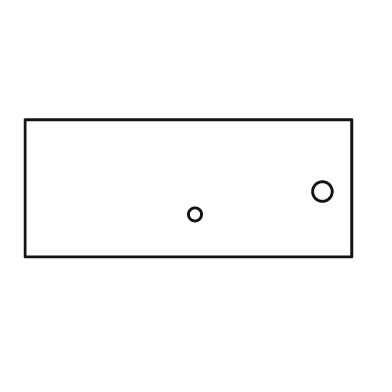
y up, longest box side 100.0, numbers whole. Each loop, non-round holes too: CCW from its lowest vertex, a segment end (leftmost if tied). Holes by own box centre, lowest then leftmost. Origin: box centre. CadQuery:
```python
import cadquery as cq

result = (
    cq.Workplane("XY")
    .moveTo(-50.0, -21.0)
    .lineTo(50.0, -21.0)
    .lineTo(50.0, 21.0)
    .lineTo(-50.0, 21.0)
    .close()
    .moveTo(2.0, -8.0)
    .circle(2.0)
    .moveTo(41.0, -1.0)
    .circle(3.0)
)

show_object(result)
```